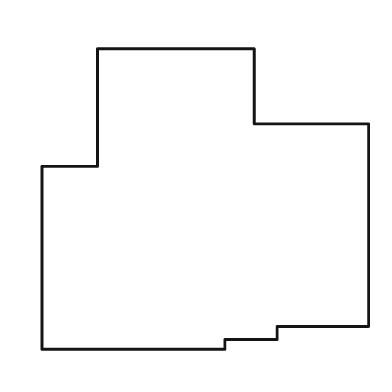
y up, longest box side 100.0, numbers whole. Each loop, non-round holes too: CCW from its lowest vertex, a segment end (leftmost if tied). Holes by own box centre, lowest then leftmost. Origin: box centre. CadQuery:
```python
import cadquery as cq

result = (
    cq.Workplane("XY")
    .moveTo(-50.0, -46.0)
    .lineTo(6.0, -46.0)
    .lineTo(6.0, -43.0)
    .lineTo(22.0, -43.0)
    .lineTo(22.0, -39.0)
    .lineTo(50.0, -39.0)
    .lineTo(50.0, 23.0)
    .lineTo(15.0, 23.0)
    .lineTo(15.0, 46.0)
    .lineTo(-33.0, 46.0)
    .lineTo(-33.0, 10.0)
    .lineTo(-50.0, 10.0)
    .close()
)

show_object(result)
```